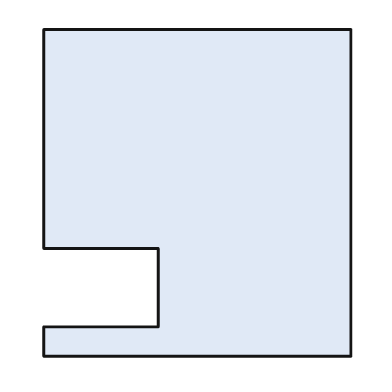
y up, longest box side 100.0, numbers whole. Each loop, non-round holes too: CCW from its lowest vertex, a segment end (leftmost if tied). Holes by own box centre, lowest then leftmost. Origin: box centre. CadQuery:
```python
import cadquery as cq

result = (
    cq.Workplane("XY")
    .moveTo(-47.0, -50.0)
    .lineTo(47.0, -50.0)
    .lineTo(47.0, 50.0)
    .lineTo(-47.0, 50.0)
    .lineTo(-47.0, -17.0)
    .lineTo(-12.0, -17.0)
    .lineTo(-12.0, -41.0)
    .lineTo(-47.0, -41.0)
    .close()
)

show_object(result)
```